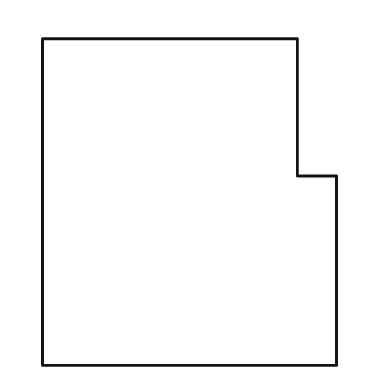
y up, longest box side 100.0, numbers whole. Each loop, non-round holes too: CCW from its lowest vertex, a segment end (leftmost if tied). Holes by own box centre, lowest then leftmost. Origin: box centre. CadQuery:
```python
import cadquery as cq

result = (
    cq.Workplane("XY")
    .moveTo(-45.0, -50.0)
    .lineTo(45.0, -50.0)
    .lineTo(45.0, 8.0)
    .lineTo(33.0, 8.0)
    .lineTo(33.0, 50.0)
    .lineTo(-45.0, 50.0)
    .close()
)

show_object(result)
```